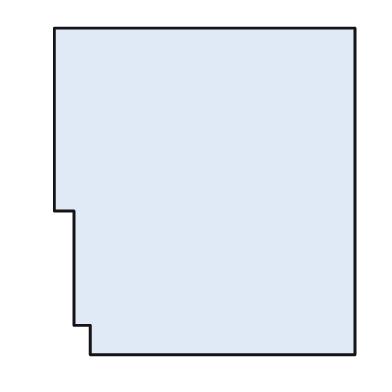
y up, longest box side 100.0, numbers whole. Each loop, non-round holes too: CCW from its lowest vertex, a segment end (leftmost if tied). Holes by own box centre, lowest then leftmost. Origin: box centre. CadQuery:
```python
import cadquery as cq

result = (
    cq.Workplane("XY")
    .moveTo(-35.0, -50.0)
    .lineTo(46.0, -50.0)
    .lineTo(46.0, 50.0)
    .lineTo(-46.0, 50.0)
    .lineTo(-46.0, -6.0)
    .lineTo(-40.0, -6.0)
    .lineTo(-40.0, -41.0)
    .lineTo(-35.0, -41.0)
    .close()
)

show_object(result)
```